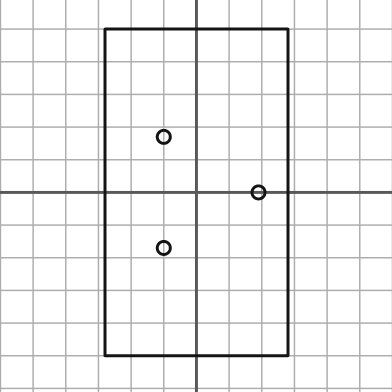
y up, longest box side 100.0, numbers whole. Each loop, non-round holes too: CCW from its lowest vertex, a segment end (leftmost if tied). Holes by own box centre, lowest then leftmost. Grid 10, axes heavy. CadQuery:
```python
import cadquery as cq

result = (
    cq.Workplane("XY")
    .moveTo(-28.0, -50.0)
    .lineTo(28.0, -50.0)
    .lineTo(28.0, 50.0)
    .lineTo(-28.0, 50.0)
    .close()
    .moveTo(-10.0, -17.0)
    .circle(2.0)
    .moveTo(19.0, 0.0)
    .circle(2.0)
    .moveTo(-10.0, 17.0)
    .circle(2.0)
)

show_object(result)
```